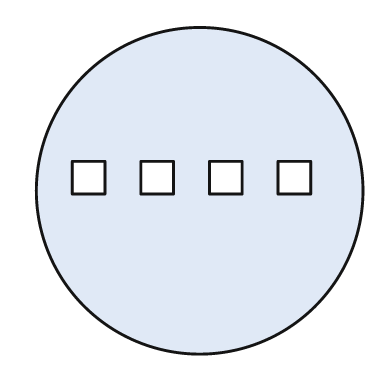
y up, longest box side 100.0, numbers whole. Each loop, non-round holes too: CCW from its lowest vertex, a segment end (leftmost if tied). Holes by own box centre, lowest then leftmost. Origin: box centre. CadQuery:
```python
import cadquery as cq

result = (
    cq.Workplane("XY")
    .moveTo(0.0, 0.0)
    .circle(50.0)
    .moveTo(-39.0, -1.0)
    .lineTo(-29.0, -1.0)
    .lineTo(-29.0, 9.0)
    .lineTo(-39.0, 9.0)
    .close()
    .moveTo(-18.0, -1.0)
    .lineTo(-8.0, -1.0)
    .lineTo(-8.0, 9.0)
    .lineTo(-18.0, 9.0)
    .close()
    .moveTo(3.0, -1.0)
    .lineTo(13.0, -1.0)
    .lineTo(13.0, 9.0)
    .lineTo(3.0, 9.0)
    .close()
    .moveTo(24.0, -1.0)
    .lineTo(34.0, -1.0)
    .lineTo(34.0, 9.0)
    .lineTo(24.0, 9.0)
    .close()
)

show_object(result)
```